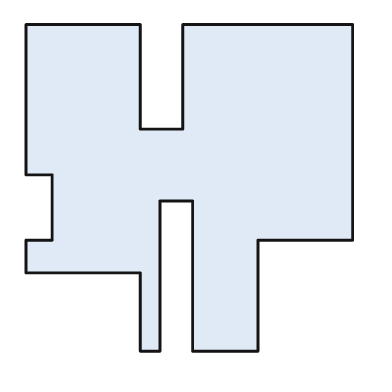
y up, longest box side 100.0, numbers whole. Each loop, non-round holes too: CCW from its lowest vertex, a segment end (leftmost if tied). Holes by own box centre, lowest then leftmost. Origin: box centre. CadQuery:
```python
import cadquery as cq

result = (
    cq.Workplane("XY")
    .moveTo(-15.0, -50.0)
    .lineTo(-9.0, -50.0)
    .lineTo(-9.0, -4.0)
    .lineTo(1.0, -4.0)
    .lineTo(1.0, -50.0)
    .lineTo(21.0, -50.0)
    .lineTo(21.0, -16.0)
    .lineTo(50.0, -16.0)
    .lineTo(50.0, 50.0)
    .lineTo(-2.0, 50.0)
    .lineTo(-2.0, 18.0)
    .lineTo(-15.0, 18.0)
    .lineTo(-15.0, 50.0)
    .lineTo(-50.0, 50.0)
    .lineTo(-50.0, 4.0)
    .lineTo(-42.0, 4.0)
    .lineTo(-42.0, -16.0)
    .lineTo(-50.0, -16.0)
    .lineTo(-50.0, -26.0)
    .lineTo(-15.0, -26.0)
    .close()
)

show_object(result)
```